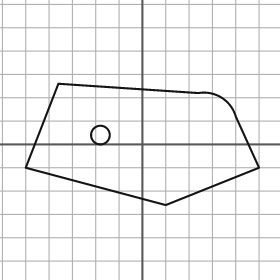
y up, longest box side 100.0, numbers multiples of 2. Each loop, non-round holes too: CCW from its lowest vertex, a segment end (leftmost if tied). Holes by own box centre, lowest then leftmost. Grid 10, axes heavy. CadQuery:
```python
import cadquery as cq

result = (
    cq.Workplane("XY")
    .moveTo(10.0, -26.0)
    .lineTo(50.0, -10.0)
    .lineTo(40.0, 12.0)
    .threePointArc((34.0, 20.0), (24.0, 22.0))
    .lineTo(-36.0, 26.0)
    .lineTo(-50.0, -10.0)
    .close()
    .moveTo(-18.0, 4.0)
    .circle(4.0)
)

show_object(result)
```